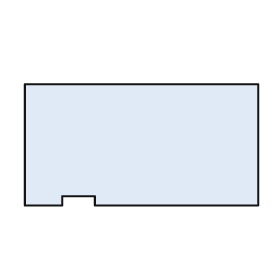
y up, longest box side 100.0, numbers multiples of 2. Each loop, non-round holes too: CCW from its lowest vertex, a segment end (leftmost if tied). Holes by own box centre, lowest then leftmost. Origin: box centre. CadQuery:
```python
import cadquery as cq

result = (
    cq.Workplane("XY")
    .moveTo(-50.0, -26.0)
    .lineTo(-34.0, -26.0)
    .lineTo(-34.0, -22.0)
    .lineTo(-20.0, -22.0)
    .lineTo(-20.0, -26.0)
    .lineTo(50.0, -26.0)
    .lineTo(50.0, 26.0)
    .lineTo(-50.0, 26.0)
    .close()
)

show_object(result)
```